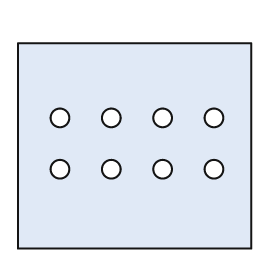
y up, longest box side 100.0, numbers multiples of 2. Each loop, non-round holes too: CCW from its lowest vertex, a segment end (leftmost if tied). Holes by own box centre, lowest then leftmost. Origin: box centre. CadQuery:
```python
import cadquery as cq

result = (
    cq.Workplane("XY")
    .moveTo(-50.0, -44.0)
    .lineTo(50.0, -44.0)
    .lineTo(50.0, 44.0)
    .lineTo(-50.0, 44.0)
    .close()
    .moveTo(-32.0, -10.0)
    .circle(4.0)
    .moveTo(-10.0, -10.0)
    .circle(4.0)
    .moveTo(12.0, -10.0)
    .circle(4.0)
    .moveTo(34.0, -10.0)
    .circle(4.0)
    .moveTo(-32.0, 12.0)
    .circle(4.0)
    .moveTo(-10.0, 12.0)
    .circle(4.0)
    .moveTo(12.0, 12.0)
    .circle(4.0)
    .moveTo(34.0, 12.0)
    .circle(4.0)
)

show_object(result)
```